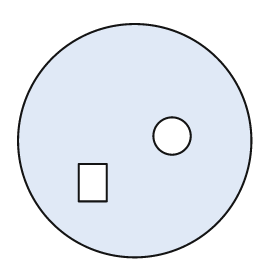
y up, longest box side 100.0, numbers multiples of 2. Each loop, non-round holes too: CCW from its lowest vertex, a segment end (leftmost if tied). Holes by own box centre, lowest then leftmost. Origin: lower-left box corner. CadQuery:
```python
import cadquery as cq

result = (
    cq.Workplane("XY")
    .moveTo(50.0, 50.0)
    .circle(50.0)
    .moveTo(26.0, 24.0)
    .lineTo(38.0, 24.0)
    .lineTo(38.0, 40.0)
    .lineTo(26.0, 40.0)
    .close()
    .moveTo(66.0, 52.0)
    .circle(8.0)
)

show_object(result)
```